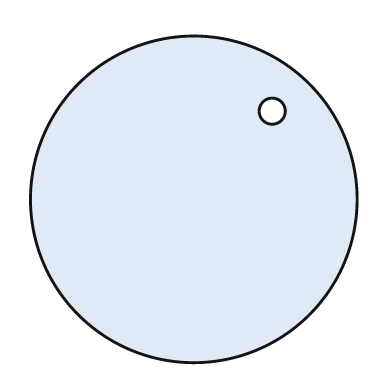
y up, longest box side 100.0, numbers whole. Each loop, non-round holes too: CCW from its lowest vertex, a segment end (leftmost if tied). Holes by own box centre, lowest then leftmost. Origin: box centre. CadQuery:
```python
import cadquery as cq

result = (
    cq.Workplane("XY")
    .moveTo(0.0, 0.0)
    .circle(50.0)
    .moveTo(24.0, 27.0)
    .circle(4.0)
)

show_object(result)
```